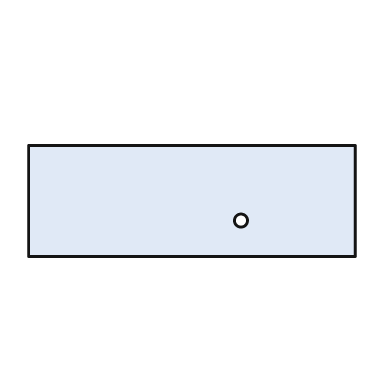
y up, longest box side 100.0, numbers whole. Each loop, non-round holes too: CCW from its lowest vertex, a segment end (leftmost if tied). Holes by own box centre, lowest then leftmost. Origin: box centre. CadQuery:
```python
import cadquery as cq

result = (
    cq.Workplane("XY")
    .moveTo(-50.0, -17.0)
    .lineTo(50.0, -17.0)
    .lineTo(50.0, 17.0)
    .lineTo(-50.0, 17.0)
    .close()
    .moveTo(15.0, -6.0)
    .circle(2.0)
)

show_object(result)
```